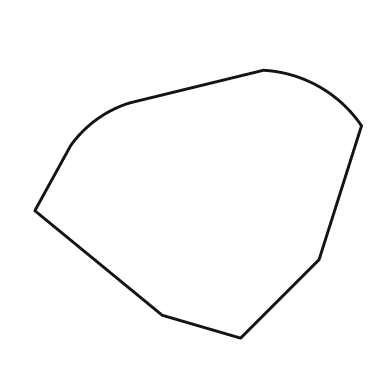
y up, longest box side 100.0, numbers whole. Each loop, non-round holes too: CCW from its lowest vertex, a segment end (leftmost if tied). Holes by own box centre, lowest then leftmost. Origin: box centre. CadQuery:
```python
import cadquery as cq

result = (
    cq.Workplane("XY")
    .moveTo(13.0, -41.0)
    .lineTo(37.0, -17.0)
    .lineTo(50.0, 24.0)
    .threePointArc((37.0, 36.0), (20.0, 41.0))
    .lineTo(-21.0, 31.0)
    .threePointArc((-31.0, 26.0), (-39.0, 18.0))
    .lineTo(-50.0, -2.0)
    .lineTo(-11.0, -34.0)
    .close()
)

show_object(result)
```